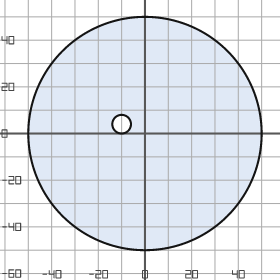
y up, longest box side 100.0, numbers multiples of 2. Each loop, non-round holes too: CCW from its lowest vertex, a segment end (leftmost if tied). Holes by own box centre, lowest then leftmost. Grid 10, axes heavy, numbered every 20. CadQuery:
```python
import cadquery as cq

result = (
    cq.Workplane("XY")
    .moveTo(0.0, 0.0)
    .circle(50.0)
    .moveTo(-10.0, 4.0)
    .circle(4.0)
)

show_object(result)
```